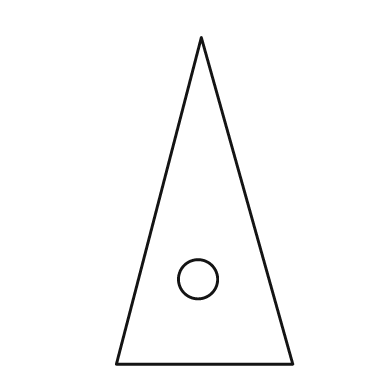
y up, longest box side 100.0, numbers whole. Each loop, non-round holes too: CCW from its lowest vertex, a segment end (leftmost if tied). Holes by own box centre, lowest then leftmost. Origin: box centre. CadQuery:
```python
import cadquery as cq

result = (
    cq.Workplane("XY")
    .moveTo(-27.0, -50.0)
    .lineTo(27.0, -50.0)
    .lineTo(-1.0, 50.0)
    .close()
    .moveTo(-2.0, -24.0)
    .circle(6.0)
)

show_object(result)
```